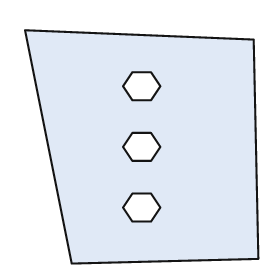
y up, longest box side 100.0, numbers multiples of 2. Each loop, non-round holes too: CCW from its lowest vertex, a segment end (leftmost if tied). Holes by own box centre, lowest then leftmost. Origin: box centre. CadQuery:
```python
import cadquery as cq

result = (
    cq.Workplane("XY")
    .moveTo(-30.0, -50.0)
    .lineTo(50.0, -48.0)
    .lineTo(48.0, 46.0)
    .lineTo(-50.0, 50.0)
    .close()
    .moveTo(-4.0, -32.0)
    .lineTo(4.0, -32.0)
    .lineTo(8.0, -26.0)
    .lineTo(4.0, -20.0)
    .lineTo(-4.0, -20.0)
    .lineTo(-8.0, -26.0)
    .close()
    .moveTo(-4.0, -6.0)
    .lineTo(4.0, -6.0)
    .lineTo(8.0, 0.0)
    .lineTo(4.0, 6.0)
    .lineTo(-4.0, 6.0)
    .lineTo(-8.0, 0.0)
    .close()
    .moveTo(-4.0, 20.0)
    .lineTo(4.0, 20.0)
    .lineTo(8.0, 26.0)
    .lineTo(4.0, 32.0)
    .lineTo(-4.0, 32.0)
    .lineTo(-8.0, 26.0)
    .close()
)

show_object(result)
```